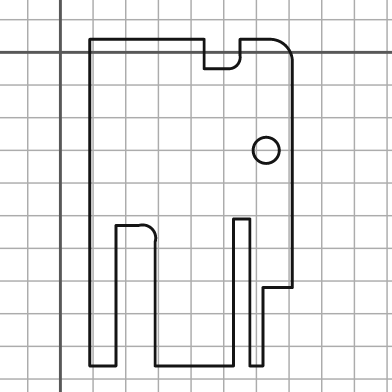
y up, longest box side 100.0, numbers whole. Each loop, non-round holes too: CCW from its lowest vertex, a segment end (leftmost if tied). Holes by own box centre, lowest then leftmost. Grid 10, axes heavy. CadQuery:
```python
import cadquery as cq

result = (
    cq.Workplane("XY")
    .moveTo(9.0, -96.0)
    .lineTo(17.0, -96.0)
    .lineTo(17.0, -53.0)
    .lineTo(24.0, -53.0)
    .threePointArc((28.0, -54.0), (29.0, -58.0))
    .lineTo(29.0, -96.0)
    .lineTo(53.0, -96.0)
    .lineTo(53.0, -51.0)
    .lineTo(58.0, -51.0)
    .lineTo(58.0, -96.0)
    .lineTo(62.0, -96.0)
    .lineTo(62.0, -72.0)
    .lineTo(71.0, -72.0)
    .lineTo(71.0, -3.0)
    .threePointArc((69.0, 2.0), (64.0, 4.0))
    .lineTo(55.0, 4.0)
    .lineTo(55.0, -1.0)
    .threePointArc((54.0, -4.0), (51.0, -5.0))
    .lineTo(44.0, -5.0)
    .lineTo(44.0, 4.0)
    .lineTo(9.0, 4.0)
    .close()
    .moveTo(63.0, -30.0)
    .circle(4.0)
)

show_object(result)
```